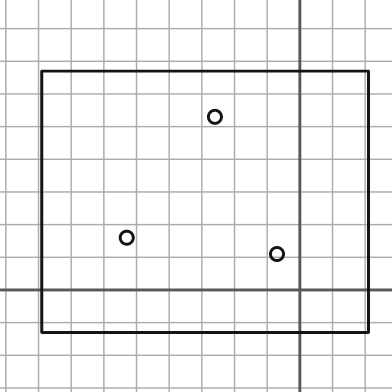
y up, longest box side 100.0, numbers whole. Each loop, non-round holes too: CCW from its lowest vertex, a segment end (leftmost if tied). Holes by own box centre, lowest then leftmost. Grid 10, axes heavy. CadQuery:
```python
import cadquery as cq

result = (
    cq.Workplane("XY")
    .moveTo(-79.0, -13.0)
    .lineTo(21.0, -13.0)
    .lineTo(21.0, 67.0)
    .lineTo(-79.0, 67.0)
    .close()
    .moveTo(-7.0, 11.0)
    .circle(2.0)
    .moveTo(-53.0, 16.0)
    .circle(2.0)
    .moveTo(-26.0, 53.0)
    .circle(2.0)
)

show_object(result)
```